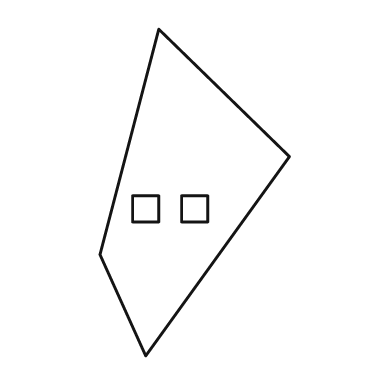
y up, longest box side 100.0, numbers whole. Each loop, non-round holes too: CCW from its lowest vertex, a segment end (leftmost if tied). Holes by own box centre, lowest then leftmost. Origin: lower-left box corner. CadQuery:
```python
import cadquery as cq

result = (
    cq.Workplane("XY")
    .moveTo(14.0, 0.0)
    .lineTo(58.0, 61.0)
    .lineTo(18.0, 100.0)
    .lineTo(0.0, 31.0)
    .close()
    .moveTo(10.0, 41.0)
    .lineTo(18.0, 41.0)
    .lineTo(18.0, 49.0)
    .lineTo(10.0, 49.0)
    .close()
    .moveTo(25.0, 41.0)
    .lineTo(33.0, 41.0)
    .lineTo(33.0, 49.0)
    .lineTo(25.0, 49.0)
    .close()
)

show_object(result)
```